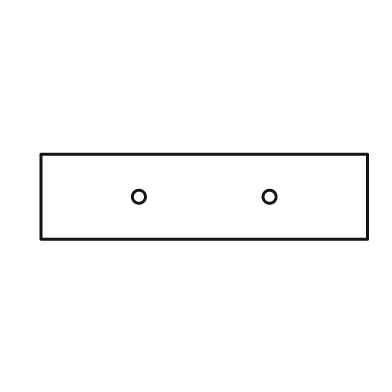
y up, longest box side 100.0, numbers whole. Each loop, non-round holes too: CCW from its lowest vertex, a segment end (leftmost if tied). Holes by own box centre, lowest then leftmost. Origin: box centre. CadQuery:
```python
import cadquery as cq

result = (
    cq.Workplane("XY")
    .moveTo(-50.0, -13.0)
    .lineTo(50.0, -13.0)
    .lineTo(50.0, 13.0)
    .lineTo(-50.0, 13.0)
    .close()
    .moveTo(-20.0, 0.0)
    .circle(2.0)
    .moveTo(20.0, 0.0)
    .circle(2.0)
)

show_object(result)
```